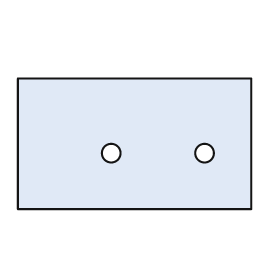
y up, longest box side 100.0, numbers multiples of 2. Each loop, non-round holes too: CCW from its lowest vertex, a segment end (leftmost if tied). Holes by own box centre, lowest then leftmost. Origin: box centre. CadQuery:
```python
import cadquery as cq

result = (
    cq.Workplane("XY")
    .moveTo(-50.0, -28.0)
    .lineTo(50.0, -28.0)
    .lineTo(50.0, 28.0)
    .lineTo(-50.0, 28.0)
    .close()
    .moveTo(-10.0, -4.0)
    .circle(4.0)
    .moveTo(30.0, -4.0)
    .circle(4.0)
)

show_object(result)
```